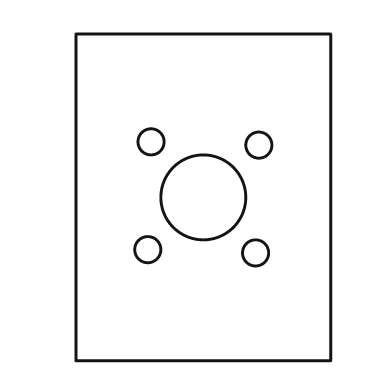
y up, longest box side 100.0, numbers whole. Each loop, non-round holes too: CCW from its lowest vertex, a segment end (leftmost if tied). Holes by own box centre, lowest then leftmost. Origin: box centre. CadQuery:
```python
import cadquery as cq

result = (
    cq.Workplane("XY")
    .moveTo(-39.0, -50.0)
    .lineTo(39.0, -50.0)
    .lineTo(39.0, 50.0)
    .lineTo(-39.0, 50.0)
    .close()
    .moveTo(16.0, -17.0)
    .circle(4.0)
    .moveTo(-17.0, -16.0)
    .circle(4.0)
    .moveTo(0.0, 0.0)
    .circle(13.0)
    .moveTo(17.0, 16.0)
    .circle(4.0)
    .moveTo(-16.0, 17.0)
    .circle(4.0)
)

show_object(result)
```